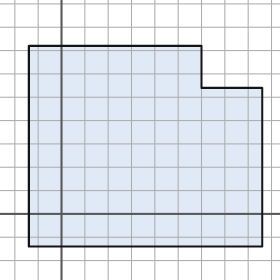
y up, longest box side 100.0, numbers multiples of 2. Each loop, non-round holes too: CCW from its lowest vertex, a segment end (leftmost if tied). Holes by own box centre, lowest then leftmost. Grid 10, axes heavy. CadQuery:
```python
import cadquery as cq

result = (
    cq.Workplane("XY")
    .moveTo(-14.0, -14.0)
    .lineTo(86.0, -14.0)
    .lineTo(86.0, 54.0)
    .lineTo(60.0, 54.0)
    .lineTo(60.0, 72.0)
    .lineTo(-14.0, 72.0)
    .close()
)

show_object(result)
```